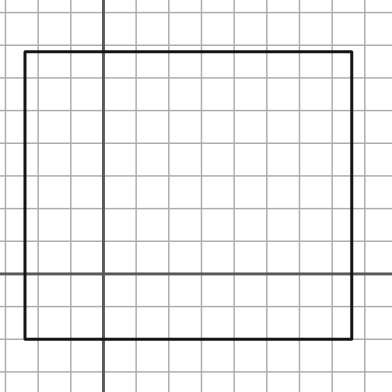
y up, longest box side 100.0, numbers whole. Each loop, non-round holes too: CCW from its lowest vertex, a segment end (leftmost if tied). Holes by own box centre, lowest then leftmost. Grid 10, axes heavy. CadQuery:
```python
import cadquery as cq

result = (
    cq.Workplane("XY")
    .moveTo(-24.0, -20.0)
    .lineTo(76.0, -20.0)
    .lineTo(76.0, 68.0)
    .lineTo(-24.0, 68.0)
    .close()
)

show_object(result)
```